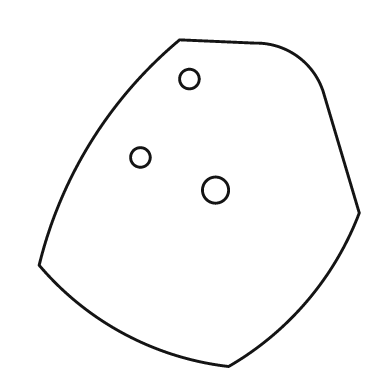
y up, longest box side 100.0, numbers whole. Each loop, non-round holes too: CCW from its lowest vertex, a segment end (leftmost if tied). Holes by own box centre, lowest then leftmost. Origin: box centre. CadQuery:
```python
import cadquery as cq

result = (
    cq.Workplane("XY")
    .moveTo(9.0, -50.0)
    .threePointArc((33.0, -30.0), (49.0, -3.0))
    .lineTo(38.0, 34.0)
    .threePointArc((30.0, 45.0), (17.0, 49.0))
    .lineTo(-6.0, 50.0)
    .threePointArc((-33.0, 19.0), (-49.0, -19.0))
    .threePointArc((-23.0, -40.0), (9.0, -50.0))
    .close()
    .moveTo(5.0, 4.0)
    .circle(4.0)
    .moveTo(-18.0, 14.0)
    .circle(3.0)
    .moveTo(-3.0, 38.0)
    .circle(3.0)
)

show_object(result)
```